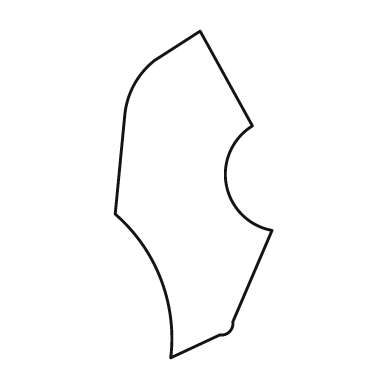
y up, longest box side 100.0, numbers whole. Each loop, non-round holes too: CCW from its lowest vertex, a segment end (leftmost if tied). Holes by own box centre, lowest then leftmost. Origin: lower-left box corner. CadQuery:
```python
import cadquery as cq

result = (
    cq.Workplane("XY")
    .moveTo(17.0, 0.0)
    .lineTo(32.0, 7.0)
    .threePointArc((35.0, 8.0), (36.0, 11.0))
    .lineTo(48.0, 39.0)
    .threePointArc((34.0, 53.0), (42.0, 71.0))
    .lineTo(26.0, 100.0)
    .lineTo(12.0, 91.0)
    .threePointArc((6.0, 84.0), (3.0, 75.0))
    .lineTo(0.0, 44.0)
    .threePointArc((14.0, 24.0), (17.0, 0.0))
    .close()
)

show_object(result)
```